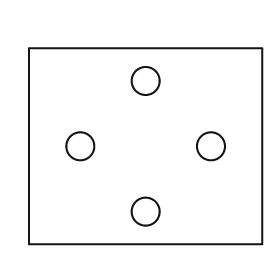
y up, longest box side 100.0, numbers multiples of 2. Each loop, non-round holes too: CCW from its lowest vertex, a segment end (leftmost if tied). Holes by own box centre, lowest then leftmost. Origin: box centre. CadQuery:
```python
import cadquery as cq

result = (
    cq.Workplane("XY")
    .moveTo(-50.0, -42.0)
    .lineTo(50.0, -42.0)
    .lineTo(50.0, 42.0)
    .lineTo(-50.0, 42.0)
    .close()
    .moveTo(0.0, -28.0)
    .circle(6.0)
    .moveTo(-28.0, 0.0)
    .circle(6.0)
    .moveTo(28.0, 0.0)
    .circle(6.0)
    .moveTo(0.0, 28.0)
    .circle(6.0)
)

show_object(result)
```